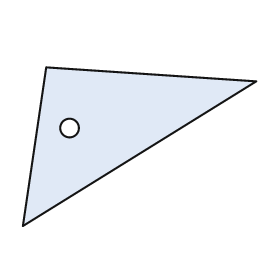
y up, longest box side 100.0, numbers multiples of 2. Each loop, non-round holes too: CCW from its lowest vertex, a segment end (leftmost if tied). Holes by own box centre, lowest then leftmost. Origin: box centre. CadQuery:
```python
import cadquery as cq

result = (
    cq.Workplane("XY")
    .moveTo(-50.0, -34.0)
    .lineTo(50.0, 28.0)
    .lineTo(-40.0, 34.0)
    .close()
    .moveTo(-30.0, 8.0)
    .circle(4.0)
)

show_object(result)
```